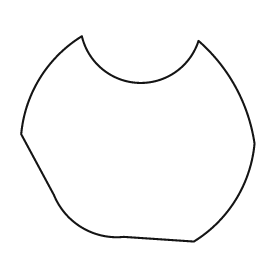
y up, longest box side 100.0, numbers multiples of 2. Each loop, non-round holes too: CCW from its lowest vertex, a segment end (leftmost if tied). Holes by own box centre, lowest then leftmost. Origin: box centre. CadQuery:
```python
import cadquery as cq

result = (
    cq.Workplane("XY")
    .moveTo(24.0, -44.0)
    .threePointArc((42.0, -26.0), (50.0, -2.0))
    .threePointArc((42.0, 22.0), (26.0, 42.0))
    .threePointArc((0.0, 24.0), (-24.0, 44.0))
    .threePointArc((-42.0, 26.0), (-50.0, 2.0))
    .lineTo(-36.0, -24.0)
    .threePointArc((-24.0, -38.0), (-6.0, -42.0))
    .close()
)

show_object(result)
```